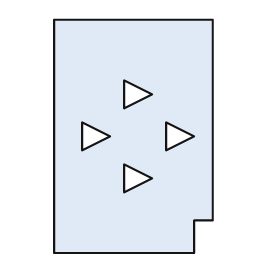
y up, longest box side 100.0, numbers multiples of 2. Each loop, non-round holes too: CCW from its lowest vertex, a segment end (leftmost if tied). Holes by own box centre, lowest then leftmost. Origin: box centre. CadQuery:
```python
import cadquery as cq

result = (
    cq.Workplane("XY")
    .moveTo(-34.0, -50.0)
    .lineTo(26.0, -50.0)
    .lineTo(26.0, -36.0)
    .lineTo(34.0, -36.0)
    .lineTo(34.0, 50.0)
    .lineTo(-34.0, 50.0)
    .close()
    .moveTo(-4.0, -24.0)
    .lineTo(8.0, -18.0)
    .lineTo(-4.0, -12.0)
    .close()
    .moveTo(-22.0, -6.0)
    .lineTo(-10.0, 0.0)
    .lineTo(-22.0, 6.0)
    .close()
    .moveTo(14.0, -6.0)
    .lineTo(26.0, 0.0)
    .lineTo(14.0, 6.0)
    .close()
    .moveTo(-4.0, 12.0)
    .lineTo(8.0, 18.0)
    .lineTo(-4.0, 24.0)
    .close()
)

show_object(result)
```